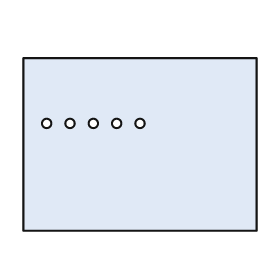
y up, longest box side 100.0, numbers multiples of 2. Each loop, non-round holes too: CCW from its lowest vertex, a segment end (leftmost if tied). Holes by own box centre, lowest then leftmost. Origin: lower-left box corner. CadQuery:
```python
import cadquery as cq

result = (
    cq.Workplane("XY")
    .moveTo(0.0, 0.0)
    .lineTo(100.0, 0.0)
    .lineTo(100.0, 74.0)
    .lineTo(0.0, 74.0)
    .close()
    .moveTo(10.0, 46.0)
    .circle(2.0)
    .moveTo(20.0, 46.0)
    .circle(2.0)
    .moveTo(30.0, 46.0)
    .circle(2.0)
    .moveTo(40.0, 46.0)
    .circle(2.0)
    .moveTo(50.0, 46.0)
    .circle(2.0)
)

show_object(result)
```